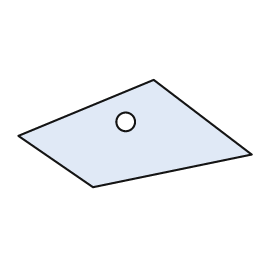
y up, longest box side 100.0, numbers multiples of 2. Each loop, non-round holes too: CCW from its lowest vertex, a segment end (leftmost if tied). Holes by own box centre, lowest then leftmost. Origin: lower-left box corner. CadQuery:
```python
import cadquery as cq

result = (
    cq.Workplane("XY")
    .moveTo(32.0, 0.0)
    .lineTo(100.0, 14.0)
    .lineTo(58.0, 46.0)
    .lineTo(0.0, 22.0)
    .close()
    .moveTo(46.0, 28.0)
    .circle(4.0)
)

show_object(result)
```